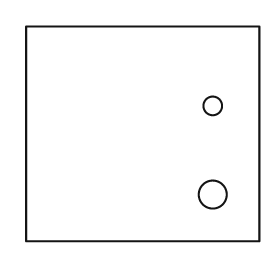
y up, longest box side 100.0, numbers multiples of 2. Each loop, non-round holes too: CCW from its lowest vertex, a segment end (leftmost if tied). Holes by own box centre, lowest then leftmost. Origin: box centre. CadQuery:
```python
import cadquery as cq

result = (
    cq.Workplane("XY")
    .moveTo(-50.0, -46.0)
    .lineTo(50.0, -46.0)
    .lineTo(50.0, 46.0)
    .lineTo(-50.0, 46.0)
    .close()
    .moveTo(30.0, -26.0)
    .circle(6.0)
    .moveTo(30.0, 12.0)
    .circle(4.0)
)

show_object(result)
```